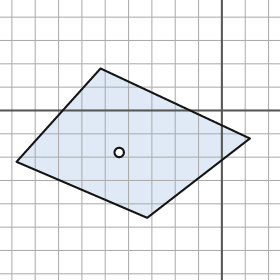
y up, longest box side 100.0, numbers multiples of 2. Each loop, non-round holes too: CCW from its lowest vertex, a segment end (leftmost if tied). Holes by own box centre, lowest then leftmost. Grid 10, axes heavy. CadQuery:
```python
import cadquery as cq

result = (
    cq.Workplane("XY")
    .moveTo(-32.0, -46.0)
    .lineTo(12.0, -12.0)
    .lineTo(-52.0, 18.0)
    .lineTo(-88.0, -22.0)
    .close()
    .moveTo(-44.0, -18.0)
    .circle(2.0)
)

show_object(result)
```